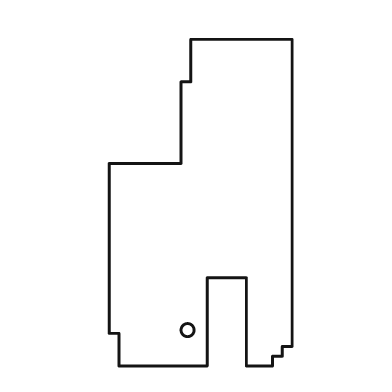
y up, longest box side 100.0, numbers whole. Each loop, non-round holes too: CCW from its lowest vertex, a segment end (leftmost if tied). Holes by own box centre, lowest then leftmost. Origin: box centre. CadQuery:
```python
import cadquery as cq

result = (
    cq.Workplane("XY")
    .moveTo(-25.0, -50.0)
    .lineTo(2.0, -50.0)
    .lineTo(2.0, -23.0)
    .lineTo(14.0, -23.0)
    .lineTo(14.0, -50.0)
    .lineTo(22.0, -50.0)
    .lineTo(22.0, -47.0)
    .lineTo(25.0, -47.0)
    .lineTo(25.0, -44.0)
    .lineTo(28.0, -44.0)
    .lineTo(28.0, 50.0)
    .lineTo(-3.0, 50.0)
    .lineTo(-3.0, 37.0)
    .lineTo(-6.0, 37.0)
    .lineTo(-6.0, 12.0)
    .lineTo(-28.0, 12.0)
    .lineTo(-28.0, -40.0)
    .lineTo(-25.0, -40.0)
    .close()
    .moveTo(-4.0, -39.0)
    .circle(2.0)
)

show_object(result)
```